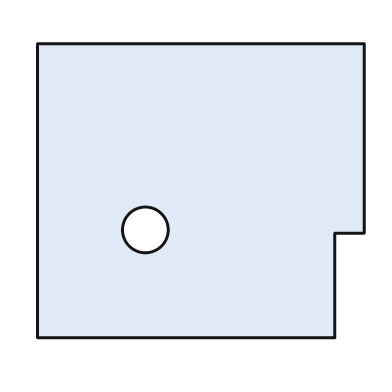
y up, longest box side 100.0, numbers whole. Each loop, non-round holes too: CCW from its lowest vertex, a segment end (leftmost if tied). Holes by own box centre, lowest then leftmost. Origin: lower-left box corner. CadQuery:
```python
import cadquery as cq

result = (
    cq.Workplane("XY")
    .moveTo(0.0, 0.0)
    .lineTo(91.0, 0.0)
    .lineTo(91.0, 32.0)
    .lineTo(100.0, 32.0)
    .lineTo(100.0, 90.0)
    .lineTo(0.0, 90.0)
    .close()
    .moveTo(33.0, 33.0)
    .circle(7.0)
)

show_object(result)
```